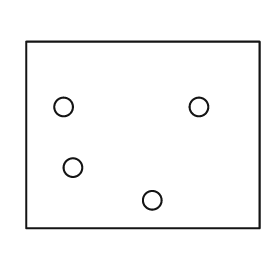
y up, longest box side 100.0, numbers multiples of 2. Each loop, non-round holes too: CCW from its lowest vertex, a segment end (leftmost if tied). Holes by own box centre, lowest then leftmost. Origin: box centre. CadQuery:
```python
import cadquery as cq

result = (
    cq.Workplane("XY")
    .moveTo(-50.0, -40.0)
    .lineTo(50.0, -40.0)
    .lineTo(50.0, 40.0)
    .lineTo(-50.0, 40.0)
    .close()
    .moveTo(4.0, -28.0)
    .circle(4.0)
    .moveTo(-30.0, -14.0)
    .circle(4.0)
    .moveTo(-34.0, 12.0)
    .circle(4.0)
    .moveTo(24.0, 12.0)
    .circle(4.0)
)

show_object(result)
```